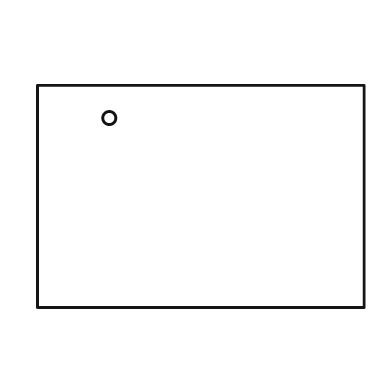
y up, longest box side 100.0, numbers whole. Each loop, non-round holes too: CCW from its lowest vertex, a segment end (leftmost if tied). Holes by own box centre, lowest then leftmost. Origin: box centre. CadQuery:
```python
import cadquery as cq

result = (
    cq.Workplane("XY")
    .moveTo(-50.0, -34.0)
    .lineTo(50.0, -34.0)
    .lineTo(50.0, 34.0)
    .lineTo(-50.0, 34.0)
    .close()
    .moveTo(-28.0, 24.0)
    .circle(2.0)
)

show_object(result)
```